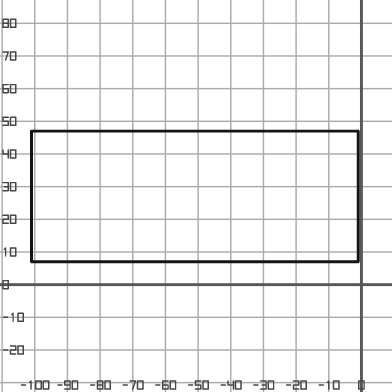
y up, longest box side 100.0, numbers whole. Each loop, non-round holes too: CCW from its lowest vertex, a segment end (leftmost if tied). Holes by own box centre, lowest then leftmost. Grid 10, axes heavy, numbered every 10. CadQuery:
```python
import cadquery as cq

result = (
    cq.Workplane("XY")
    .moveTo(-101.0, 7.0)
    .lineTo(-1.0, 7.0)
    .lineTo(-1.0, 47.0)
    .lineTo(-101.0, 47.0)
    .close()
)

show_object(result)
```